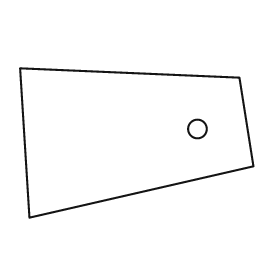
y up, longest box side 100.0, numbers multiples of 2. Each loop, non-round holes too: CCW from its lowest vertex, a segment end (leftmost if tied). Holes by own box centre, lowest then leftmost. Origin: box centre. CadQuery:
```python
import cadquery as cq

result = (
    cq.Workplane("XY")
    .moveTo(-46.0, -32.0)
    .lineTo(50.0, -10.0)
    .lineTo(44.0, 28.0)
    .lineTo(-50.0, 32.0)
    .close()
    .moveTo(26.0, 6.0)
    .circle(4.0)
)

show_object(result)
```